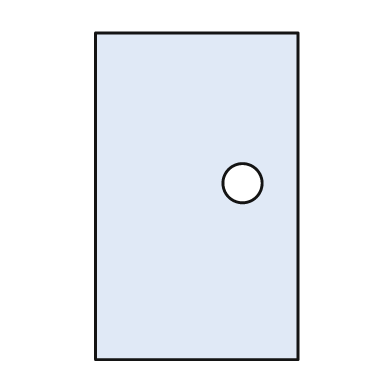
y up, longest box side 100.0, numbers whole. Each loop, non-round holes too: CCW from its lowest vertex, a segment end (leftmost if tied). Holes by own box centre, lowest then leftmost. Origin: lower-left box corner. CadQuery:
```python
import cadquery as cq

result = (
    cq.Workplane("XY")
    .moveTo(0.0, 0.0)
    .lineTo(62.0, 0.0)
    .lineTo(62.0, 100.0)
    .lineTo(0.0, 100.0)
    .close()
    .moveTo(45.0, 54.0)
    .circle(6.0)
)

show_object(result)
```